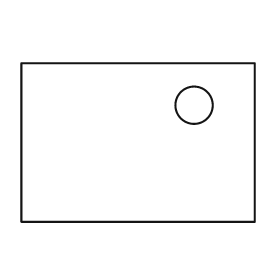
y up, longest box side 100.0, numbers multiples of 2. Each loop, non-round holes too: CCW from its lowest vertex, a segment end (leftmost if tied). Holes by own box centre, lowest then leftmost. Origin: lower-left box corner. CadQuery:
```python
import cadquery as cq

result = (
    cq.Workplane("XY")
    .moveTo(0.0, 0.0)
    .lineTo(100.0, 0.0)
    .lineTo(100.0, 68.0)
    .lineTo(0.0, 68.0)
    .close()
    .moveTo(74.0, 50.0)
    .circle(8.0)
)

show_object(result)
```